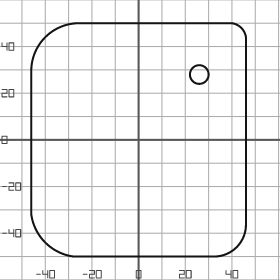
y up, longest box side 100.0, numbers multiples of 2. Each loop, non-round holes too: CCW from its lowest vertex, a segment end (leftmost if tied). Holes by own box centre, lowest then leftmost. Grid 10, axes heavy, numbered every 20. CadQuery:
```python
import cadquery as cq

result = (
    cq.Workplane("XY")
    .moveTo(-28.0, -50.0)
    .lineTo(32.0, -50.0)
    .threePointArc((42.0, -46.0), (46.0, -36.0))
    .lineTo(46.0, 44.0)
    .threePointArc((44.0, 48.0), (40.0, 50.0))
    .lineTo(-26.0, 50.0)
    .threePointArc((-40.0, 44.0), (-46.0, 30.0))
    .lineTo(-46.0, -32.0)
    .threePointArc((-40.0, -44.0), (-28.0, -50.0))
    .close()
    .moveTo(26.0, 28.0)
    .circle(4.0)
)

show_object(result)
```